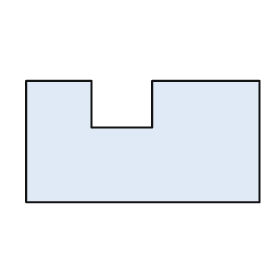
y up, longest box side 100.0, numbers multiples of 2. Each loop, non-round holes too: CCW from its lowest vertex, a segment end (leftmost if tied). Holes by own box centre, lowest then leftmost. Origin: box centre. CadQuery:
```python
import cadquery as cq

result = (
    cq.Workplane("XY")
    .moveTo(-50.0, -26.0)
    .lineTo(50.0, -26.0)
    .lineTo(50.0, 26.0)
    .lineTo(4.0, 26.0)
    .lineTo(4.0, 6.0)
    .lineTo(-22.0, 6.0)
    .lineTo(-22.0, 26.0)
    .lineTo(-50.0, 26.0)
    .close()
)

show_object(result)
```